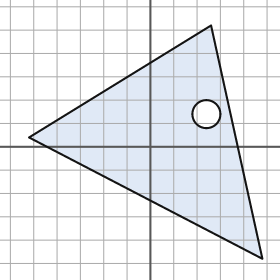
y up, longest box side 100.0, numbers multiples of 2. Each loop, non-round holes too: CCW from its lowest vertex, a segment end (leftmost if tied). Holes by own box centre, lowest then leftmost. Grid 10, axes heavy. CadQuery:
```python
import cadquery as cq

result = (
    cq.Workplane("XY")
    .moveTo(48.0, -48.0)
    .lineTo(26.0, 52.0)
    .lineTo(-52.0, 4.0)
    .close()
    .moveTo(24.0, 14.0)
    .circle(6.0)
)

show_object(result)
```